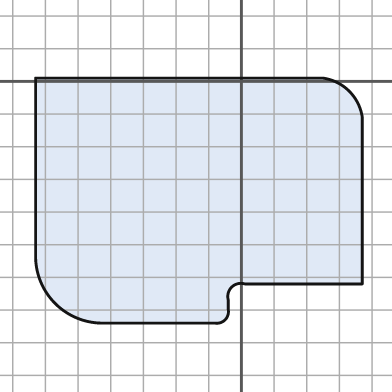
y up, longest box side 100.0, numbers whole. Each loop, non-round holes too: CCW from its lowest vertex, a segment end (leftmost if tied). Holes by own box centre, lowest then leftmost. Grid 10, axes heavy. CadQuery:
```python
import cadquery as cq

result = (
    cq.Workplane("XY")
    .moveTo(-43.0, -74.0)
    .lineTo(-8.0, -74.0)
    .threePointArc((-5.0, -73.0), (-4.0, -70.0))
    .lineTo(-4.0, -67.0)
    .threePointArc((-3.0, -63.0), (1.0, -62.0))
    .lineTo(37.0, -62.0)
    .lineTo(37.0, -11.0)
    .threePointArc((33.0, -3.0), (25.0, 1.0))
    .lineTo(-63.0, 1.0)
    .lineTo(-63.0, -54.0)
    .threePointArc((-57.0, -68.0), (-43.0, -74.0))
    .close()
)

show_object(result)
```